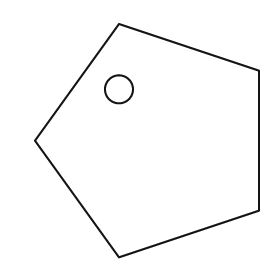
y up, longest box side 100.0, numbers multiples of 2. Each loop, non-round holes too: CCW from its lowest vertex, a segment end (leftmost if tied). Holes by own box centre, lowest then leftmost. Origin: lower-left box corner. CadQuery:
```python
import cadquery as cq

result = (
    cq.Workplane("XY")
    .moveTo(36.0, 0.0)
    .lineTo(96.0, 20.0)
    .lineTo(96.0, 80.0)
    .lineTo(36.0, 100.0)
    .lineTo(0.0, 50.0)
    .close()
    .moveTo(36.0, 72.0)
    .circle(6.0)
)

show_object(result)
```